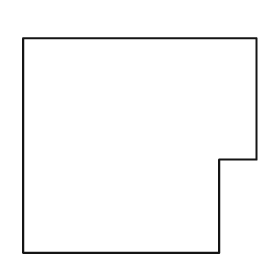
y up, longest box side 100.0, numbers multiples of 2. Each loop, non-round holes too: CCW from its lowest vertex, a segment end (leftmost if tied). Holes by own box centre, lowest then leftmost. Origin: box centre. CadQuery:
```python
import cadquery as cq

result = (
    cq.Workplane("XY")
    .moveTo(-50.0, -46.0)
    .lineTo(34.0, -46.0)
    .lineTo(34.0, -6.0)
    .lineTo(50.0, -6.0)
    .lineTo(50.0, 46.0)
    .lineTo(-50.0, 46.0)
    .close()
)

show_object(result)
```